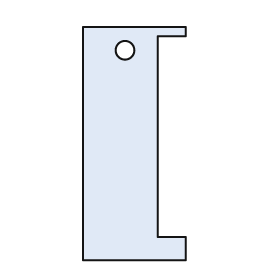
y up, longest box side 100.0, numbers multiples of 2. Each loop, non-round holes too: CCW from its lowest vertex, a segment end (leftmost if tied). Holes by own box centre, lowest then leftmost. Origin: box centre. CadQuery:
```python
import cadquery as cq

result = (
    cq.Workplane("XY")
    .moveTo(-22.0, -50.0)
    .lineTo(22.0, -50.0)
    .lineTo(22.0, -40.0)
    .lineTo(10.0, -40.0)
    .lineTo(10.0, 46.0)
    .lineTo(22.0, 46.0)
    .lineTo(22.0, 50.0)
    .lineTo(-22.0, 50.0)
    .close()
    .moveTo(-4.0, 40.0)
    .circle(4.0)
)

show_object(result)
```